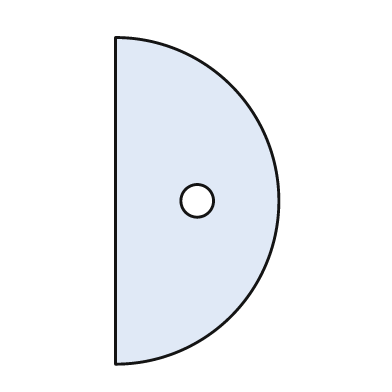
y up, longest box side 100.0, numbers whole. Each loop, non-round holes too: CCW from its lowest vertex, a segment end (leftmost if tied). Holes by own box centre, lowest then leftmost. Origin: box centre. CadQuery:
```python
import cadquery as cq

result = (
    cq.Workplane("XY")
    .moveTo(-25.0, -50.0)
    .threePointArc((25.0, 0.0), (-25.0, 50.0))
    .close()
    .moveTo(0.0, 0.0)
    .circle(5.0)
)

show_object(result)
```